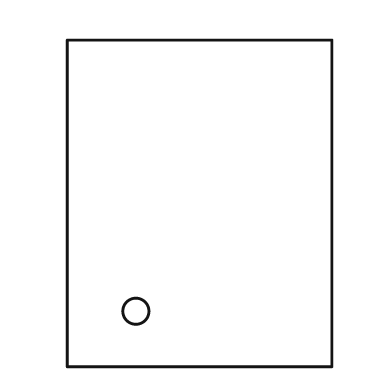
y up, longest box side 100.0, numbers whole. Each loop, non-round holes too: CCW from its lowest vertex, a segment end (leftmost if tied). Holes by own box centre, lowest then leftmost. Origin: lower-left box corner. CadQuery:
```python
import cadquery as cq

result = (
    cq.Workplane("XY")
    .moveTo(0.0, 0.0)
    .lineTo(81.0, 0.0)
    .lineTo(81.0, 100.0)
    .lineTo(0.0, 100.0)
    .close()
    .moveTo(21.0, 17.0)
    .circle(4.0)
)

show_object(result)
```